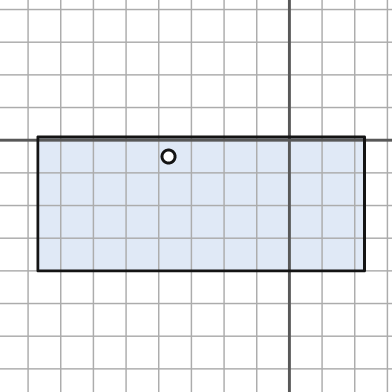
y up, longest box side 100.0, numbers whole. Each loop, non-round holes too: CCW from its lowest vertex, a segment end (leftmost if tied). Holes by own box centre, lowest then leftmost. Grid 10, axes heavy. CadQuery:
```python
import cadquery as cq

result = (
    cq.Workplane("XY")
    .moveTo(-77.0, -40.0)
    .lineTo(23.0, -40.0)
    .lineTo(23.0, 1.0)
    .lineTo(-77.0, 1.0)
    .close()
    .moveTo(-37.0, -5.0)
    .circle(2.0)
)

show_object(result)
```